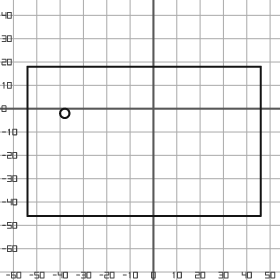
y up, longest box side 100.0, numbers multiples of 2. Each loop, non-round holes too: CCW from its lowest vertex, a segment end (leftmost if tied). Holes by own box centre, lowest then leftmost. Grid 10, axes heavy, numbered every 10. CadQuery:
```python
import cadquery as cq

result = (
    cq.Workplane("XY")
    .moveTo(-54.0, -46.0)
    .lineTo(46.0, -46.0)
    .lineTo(46.0, 18.0)
    .lineTo(-54.0, 18.0)
    .close()
    .moveTo(-38.0, -2.0)
    .circle(2.0)
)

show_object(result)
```